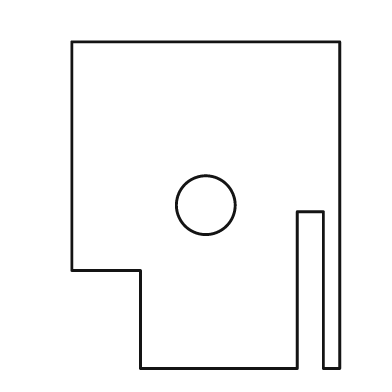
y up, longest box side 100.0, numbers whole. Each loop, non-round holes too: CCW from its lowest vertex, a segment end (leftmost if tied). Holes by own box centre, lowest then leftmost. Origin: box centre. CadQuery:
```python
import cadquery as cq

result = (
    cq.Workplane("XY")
    .moveTo(-20.0, -50.0)
    .lineTo(28.0, -50.0)
    .lineTo(28.0, -2.0)
    .lineTo(36.0, -2.0)
    .lineTo(36.0, -50.0)
    .lineTo(41.0, -50.0)
    .lineTo(41.0, 50.0)
    .lineTo(-41.0, 50.0)
    .lineTo(-41.0, -20.0)
    .lineTo(-20.0, -20.0)
    .close()
    .moveTo(0.0, 0.0)
    .circle(9.0)
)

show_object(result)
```